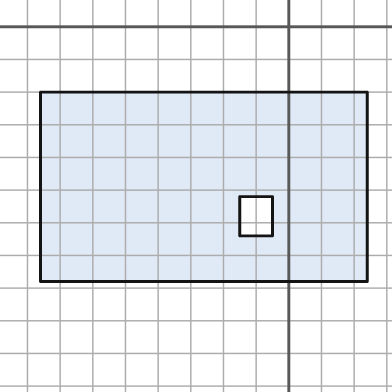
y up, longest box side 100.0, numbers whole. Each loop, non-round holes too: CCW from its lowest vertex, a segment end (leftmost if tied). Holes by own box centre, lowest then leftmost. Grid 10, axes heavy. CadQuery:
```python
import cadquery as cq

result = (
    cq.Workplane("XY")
    .moveTo(-76.0, -78.0)
    .lineTo(24.0, -78.0)
    .lineTo(24.0, -20.0)
    .lineTo(-76.0, -20.0)
    .close()
    .moveTo(-15.0, -64.0)
    .lineTo(-5.0, -64.0)
    .lineTo(-5.0, -52.0)
    .lineTo(-15.0, -52.0)
    .close()
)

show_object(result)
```